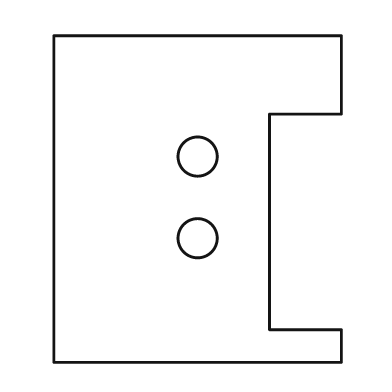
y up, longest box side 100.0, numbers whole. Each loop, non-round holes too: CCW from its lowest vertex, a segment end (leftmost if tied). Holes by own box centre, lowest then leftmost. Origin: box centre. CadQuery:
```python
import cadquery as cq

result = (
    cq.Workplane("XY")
    .moveTo(-44.0, -50.0)
    .lineTo(44.0, -50.0)
    .lineTo(44.0, -40.0)
    .lineTo(22.0, -40.0)
    .lineTo(22.0, 26.0)
    .lineTo(44.0, 26.0)
    .lineTo(44.0, 50.0)
    .lineTo(-44.0, 50.0)
    .close()
    .moveTo(0.0, -12.0)
    .circle(6.0)
    .moveTo(0.0, 13.0)
    .circle(6.0)
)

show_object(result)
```